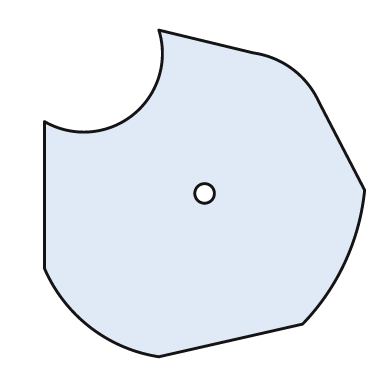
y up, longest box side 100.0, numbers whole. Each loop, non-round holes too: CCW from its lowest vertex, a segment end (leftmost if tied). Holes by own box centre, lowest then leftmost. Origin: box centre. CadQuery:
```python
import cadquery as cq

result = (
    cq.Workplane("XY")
    .moveTo(-14.0, -50.0)
    .lineTo(30.0, -40.0)
    .threePointArc((43.0, -21.0), (49.0, 1.0))
    .lineTo(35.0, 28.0)
    .threePointArc((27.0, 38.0), (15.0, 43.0))
    .lineTo(-14.0, 50.0)
    .threePointArc((-22.0, 24.0), (-49.0, 22.0))
    .lineTo(-49.0, -23.0)
    .threePointArc((-35.0, -41.0), (-14.0, -50.0))
    .close()
    .moveTo(0.0, 0.0)
    .circle(3.0)
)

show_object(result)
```